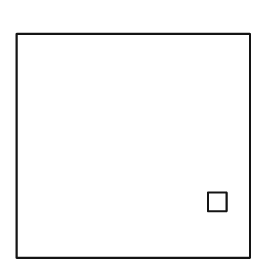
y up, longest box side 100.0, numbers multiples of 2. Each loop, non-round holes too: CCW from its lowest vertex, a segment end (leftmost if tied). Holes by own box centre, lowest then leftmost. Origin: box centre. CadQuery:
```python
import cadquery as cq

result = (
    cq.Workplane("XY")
    .moveTo(-50.0, -48.0)
    .lineTo(50.0, -48.0)
    .lineTo(50.0, 48.0)
    .lineTo(-50.0, 48.0)
    .close()
    .moveTo(32.0, -28.0)
    .lineTo(40.0, -28.0)
    .lineTo(40.0, -20.0)
    .lineTo(32.0, -20.0)
    .close()
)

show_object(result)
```